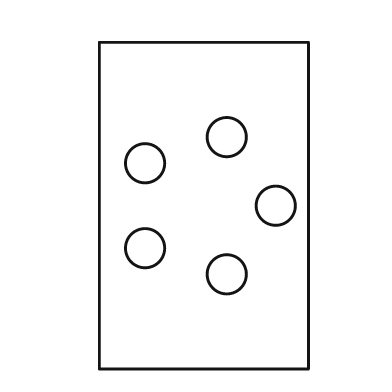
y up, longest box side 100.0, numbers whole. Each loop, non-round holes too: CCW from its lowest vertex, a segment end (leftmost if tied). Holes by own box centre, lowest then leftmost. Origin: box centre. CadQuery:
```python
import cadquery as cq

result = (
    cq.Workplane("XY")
    .moveTo(-32.0, -50.0)
    .lineTo(32.0, -50.0)
    .lineTo(32.0, 50.0)
    .lineTo(-32.0, 50.0)
    .close()
    .moveTo(7.0, -21.0)
    .circle(6.0)
    .moveTo(-18.0, -13.0)
    .circle(6.0)
    .moveTo(22.0, 0.0)
    .circle(6.0)
    .moveTo(-18.0, 13.0)
    .circle(6.0)
    .moveTo(7.0, 21.0)
    .circle(6.0)
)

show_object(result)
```